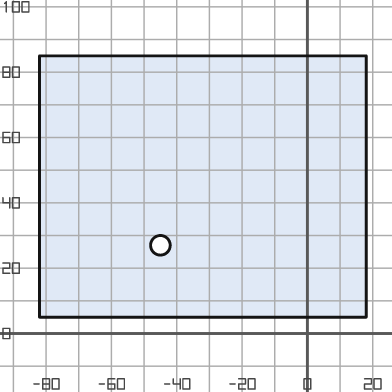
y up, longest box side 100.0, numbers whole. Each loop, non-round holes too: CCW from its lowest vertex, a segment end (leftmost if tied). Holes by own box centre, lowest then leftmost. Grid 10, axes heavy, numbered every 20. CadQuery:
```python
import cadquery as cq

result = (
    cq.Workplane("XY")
    .moveTo(-82.0, 5.0)
    .lineTo(18.0, 5.0)
    .lineTo(18.0, 85.0)
    .lineTo(-82.0, 85.0)
    .close()
    .moveTo(-45.0, 27.0)
    .circle(3.0)
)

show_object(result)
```